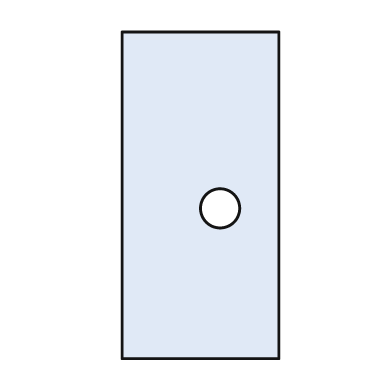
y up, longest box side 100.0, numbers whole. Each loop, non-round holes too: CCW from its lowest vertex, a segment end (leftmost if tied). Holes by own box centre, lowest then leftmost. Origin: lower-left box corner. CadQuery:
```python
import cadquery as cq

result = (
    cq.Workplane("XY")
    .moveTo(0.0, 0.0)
    .lineTo(48.0, 0.0)
    .lineTo(48.0, 100.0)
    .lineTo(0.0, 100.0)
    .close()
    .moveTo(30.0, 46.0)
    .circle(6.0)
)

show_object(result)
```